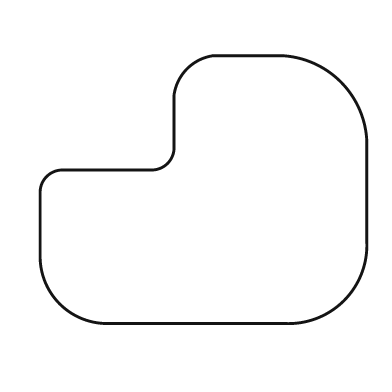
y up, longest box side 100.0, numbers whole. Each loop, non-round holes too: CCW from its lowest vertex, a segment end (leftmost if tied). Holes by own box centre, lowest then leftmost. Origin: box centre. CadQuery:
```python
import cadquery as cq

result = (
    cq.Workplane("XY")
    .moveTo(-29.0, -41.0)
    .lineTo(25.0, -41.0)
    .threePointArc((43.0, -34.0), (50.0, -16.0))
    .lineTo(50.0, 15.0)
    .threePointArc((42.0, 33.0), (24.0, 41.0))
    .lineTo(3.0, 41.0)
    .threePointArc((-5.0, 37.0), (-9.0, 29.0))
    .lineTo(-9.0, 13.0)
    .threePointArc((-11.0, 8.0), (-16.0, 6.0))
    .lineTo(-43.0, 6.0)
    .threePointArc((-48.0, 4.0), (-50.0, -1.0))
    .lineTo(-50.0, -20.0)
    .threePointArc((-44.0, -35.0), (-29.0, -41.0))
    .close()
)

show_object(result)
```